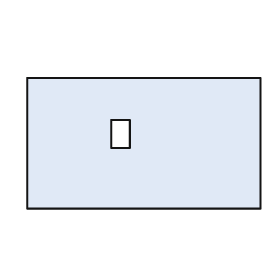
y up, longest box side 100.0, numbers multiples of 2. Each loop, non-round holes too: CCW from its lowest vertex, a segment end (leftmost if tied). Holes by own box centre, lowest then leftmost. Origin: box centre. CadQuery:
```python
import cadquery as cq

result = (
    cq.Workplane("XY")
    .moveTo(-50.0, -28.0)
    .lineTo(50.0, -28.0)
    .lineTo(50.0, 28.0)
    .lineTo(-50.0, 28.0)
    .close()
    .moveTo(-14.0, -2.0)
    .lineTo(-6.0, -2.0)
    .lineTo(-6.0, 10.0)
    .lineTo(-14.0, 10.0)
    .close()
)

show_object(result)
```